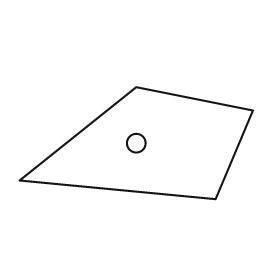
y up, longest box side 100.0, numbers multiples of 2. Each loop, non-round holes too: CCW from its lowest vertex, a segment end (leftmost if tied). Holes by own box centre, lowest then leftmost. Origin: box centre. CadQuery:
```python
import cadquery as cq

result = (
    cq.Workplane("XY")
    .moveTo(34.0, -24.0)
    .lineTo(50.0, 14.0)
    .lineTo(0.0, 24.0)
    .lineTo(-50.0, -16.0)
    .close()
    .moveTo(0.0, 0.0)
    .circle(4.0)
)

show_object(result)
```